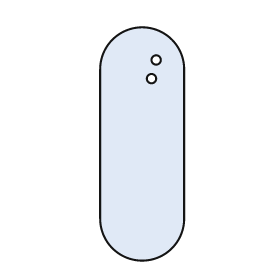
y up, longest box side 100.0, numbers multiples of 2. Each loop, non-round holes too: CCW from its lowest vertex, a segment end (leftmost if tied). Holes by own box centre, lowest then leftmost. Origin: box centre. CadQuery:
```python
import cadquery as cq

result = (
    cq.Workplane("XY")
    .moveTo(-18.0, -32.0)
    .threePointArc((0.0, -50.0), (18.0, -32.0))
    .lineTo(18.0, 32.0)
    .threePointArc((0.0, 50.0), (-18.0, 32.0))
    .close()
    .moveTo(4.0, 28.0)
    .circle(2.0)
    .moveTo(6.0, 36.0)
    .circle(2.0)
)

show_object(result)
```